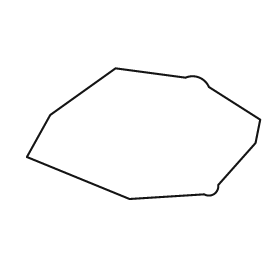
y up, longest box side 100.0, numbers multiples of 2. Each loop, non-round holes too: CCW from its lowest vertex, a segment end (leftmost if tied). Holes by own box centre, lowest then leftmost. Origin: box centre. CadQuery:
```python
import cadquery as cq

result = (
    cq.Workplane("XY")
    .moveTo(-6.0, -28.0)
    .lineTo(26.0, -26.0)
    .threePointArc((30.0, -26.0), (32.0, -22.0))
    .lineTo(48.0, -4.0)
    .lineTo(50.0, 6.0)
    .lineTo(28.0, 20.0)
    .threePointArc((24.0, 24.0), (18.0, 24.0))
    .lineTo(-12.0, 28.0)
    .lineTo(-40.0, 8.0)
    .lineTo(-50.0, -10.0)
    .close()
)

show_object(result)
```